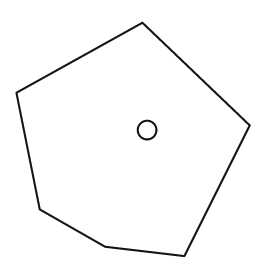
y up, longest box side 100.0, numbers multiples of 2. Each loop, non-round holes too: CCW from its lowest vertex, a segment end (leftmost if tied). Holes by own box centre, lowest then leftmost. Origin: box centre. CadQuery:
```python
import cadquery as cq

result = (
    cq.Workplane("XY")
    .moveTo(22.0, -50.0)
    .lineTo(50.0, 6.0)
    .lineTo(4.0, 50.0)
    .lineTo(-50.0, 20.0)
    .lineTo(-40.0, -30.0)
    .lineTo(-12.0, -46.0)
    .close()
    .moveTo(6.0, 4.0)
    .circle(4.0)
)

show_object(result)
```